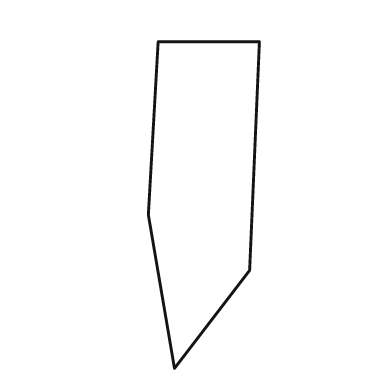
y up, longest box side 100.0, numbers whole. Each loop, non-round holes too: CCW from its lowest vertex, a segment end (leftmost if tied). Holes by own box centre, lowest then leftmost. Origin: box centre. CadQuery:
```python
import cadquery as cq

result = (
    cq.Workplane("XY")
    .moveTo(-9.0, -50.0)
    .lineTo(14.0, -20.0)
    .lineTo(17.0, 50.0)
    .lineTo(-14.0, 50.0)
    .lineTo(-17.0, -3.0)
    .close()
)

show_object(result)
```